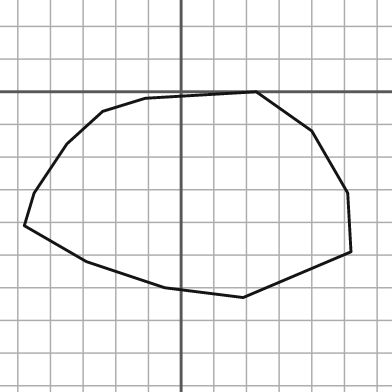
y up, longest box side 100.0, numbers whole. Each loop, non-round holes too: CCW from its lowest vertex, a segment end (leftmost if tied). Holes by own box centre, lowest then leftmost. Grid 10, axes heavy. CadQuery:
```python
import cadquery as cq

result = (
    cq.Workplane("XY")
    .moveTo(19.0, -63.0)
    .lineTo(52.0, -49.0)
    .lineTo(51.0, -31.0)
    .lineTo(40.0, -12.0)
    .lineTo(23.0, 0.0)
    .lineTo(-11.0, -2.0)
    .lineTo(-24.0, -6.0)
    .lineTo(-35.0, -16.0)
    .lineTo(-45.0, -31.0)
    .lineTo(-48.0, -41.0)
    .lineTo(-29.0, -52.0)
    .lineTo(-5.0, -60.0)
    .close()
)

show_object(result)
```